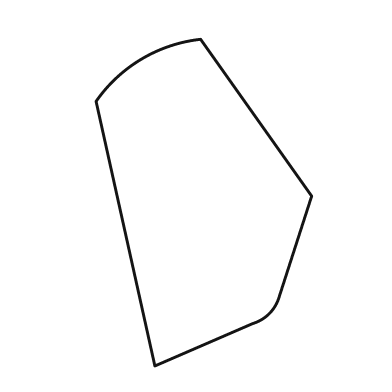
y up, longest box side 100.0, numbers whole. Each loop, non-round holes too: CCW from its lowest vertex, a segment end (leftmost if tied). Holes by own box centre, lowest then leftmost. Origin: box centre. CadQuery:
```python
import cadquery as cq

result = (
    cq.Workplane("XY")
    .moveTo(-15.0, -50.0)
    .lineTo(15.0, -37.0)
    .threePointArc((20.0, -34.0), (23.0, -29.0))
    .lineTo(33.0, 2.0)
    .lineTo(-1.0, 50.0)
    .threePointArc((-19.0, 44.0), (-33.0, 31.0))
    .close()
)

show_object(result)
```